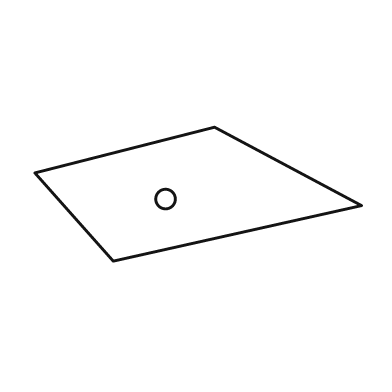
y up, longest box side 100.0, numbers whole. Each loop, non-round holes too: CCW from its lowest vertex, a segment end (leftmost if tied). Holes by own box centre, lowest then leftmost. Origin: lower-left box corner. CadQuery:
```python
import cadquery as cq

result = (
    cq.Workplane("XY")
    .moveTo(24.0, 0.0)
    .lineTo(100.0, 17.0)
    .lineTo(55.0, 41.0)
    .lineTo(0.0, 27.0)
    .close()
    .moveTo(40.0, 19.0)
    .circle(3.0)
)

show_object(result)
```